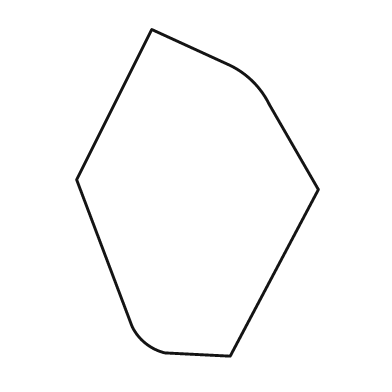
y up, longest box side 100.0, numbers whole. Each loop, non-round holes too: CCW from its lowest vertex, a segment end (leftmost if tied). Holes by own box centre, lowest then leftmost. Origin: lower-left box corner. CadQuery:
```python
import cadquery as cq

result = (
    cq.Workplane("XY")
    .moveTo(47.0, 0.0)
    .lineTo(74.0, 51.0)
    .lineTo(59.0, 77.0)
    .threePointArc((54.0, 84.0), (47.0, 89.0))
    .lineTo(23.0, 100.0)
    .lineTo(0.0, 54.0)
    .lineTo(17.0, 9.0)
    .threePointArc((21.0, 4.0), (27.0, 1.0))
    .close()
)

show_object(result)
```